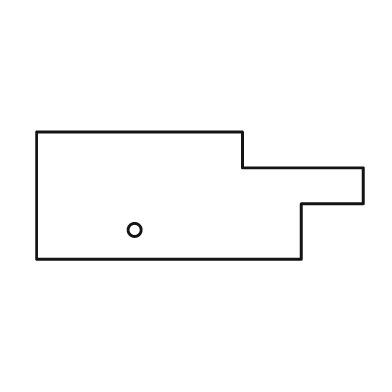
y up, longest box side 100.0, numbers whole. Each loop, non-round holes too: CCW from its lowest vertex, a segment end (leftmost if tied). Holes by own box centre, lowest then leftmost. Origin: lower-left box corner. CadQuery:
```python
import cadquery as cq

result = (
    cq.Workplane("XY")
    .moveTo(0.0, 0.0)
    .lineTo(81.0, 0.0)
    .lineTo(81.0, 17.0)
    .lineTo(100.0, 17.0)
    .lineTo(100.0, 28.0)
    .lineTo(63.0, 28.0)
    .lineTo(63.0, 39.0)
    .lineTo(0.0, 39.0)
    .close()
    .moveTo(30.0, 9.0)
    .circle(2.0)
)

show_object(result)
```